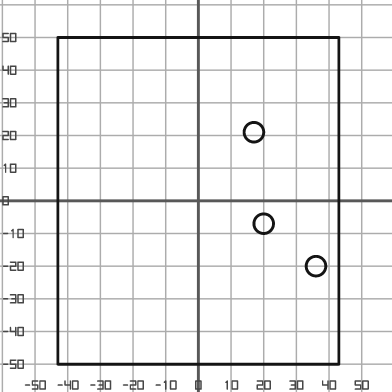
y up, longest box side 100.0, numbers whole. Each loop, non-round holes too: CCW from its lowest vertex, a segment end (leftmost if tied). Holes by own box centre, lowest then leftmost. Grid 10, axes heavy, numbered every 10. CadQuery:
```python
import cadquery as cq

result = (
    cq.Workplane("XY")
    .moveTo(-43.0, -50.0)
    .lineTo(43.0, -50.0)
    .lineTo(43.0, 50.0)
    .lineTo(-43.0, 50.0)
    .close()
    .moveTo(36.0, -20.0)
    .circle(3.0)
    .moveTo(20.0, -7.0)
    .circle(3.0)
    .moveTo(17.0, 21.0)
    .circle(3.0)
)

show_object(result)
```